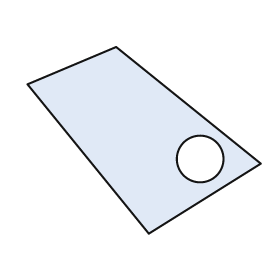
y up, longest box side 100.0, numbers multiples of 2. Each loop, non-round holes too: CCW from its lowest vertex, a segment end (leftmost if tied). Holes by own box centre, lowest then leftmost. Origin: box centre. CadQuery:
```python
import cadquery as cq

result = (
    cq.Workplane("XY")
    .moveTo(2.0, -40.0)
    .lineTo(50.0, -10.0)
    .lineTo(-12.0, 40.0)
    .lineTo(-50.0, 24.0)
    .close()
    .moveTo(24.0, -8.0)
    .circle(10.0)
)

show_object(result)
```